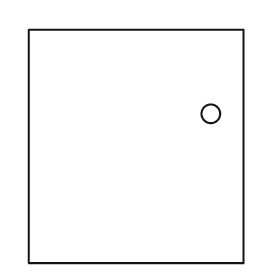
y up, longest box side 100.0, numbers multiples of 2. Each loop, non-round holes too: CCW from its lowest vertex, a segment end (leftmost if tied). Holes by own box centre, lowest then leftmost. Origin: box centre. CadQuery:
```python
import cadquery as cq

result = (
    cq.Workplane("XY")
    .moveTo(-46.0, -50.0)
    .lineTo(46.0, -50.0)
    .lineTo(46.0, 50.0)
    .lineTo(-46.0, 50.0)
    .close()
    .moveTo(32.0, 14.0)
    .circle(4.0)
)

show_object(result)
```